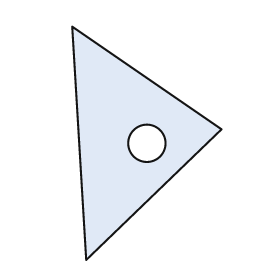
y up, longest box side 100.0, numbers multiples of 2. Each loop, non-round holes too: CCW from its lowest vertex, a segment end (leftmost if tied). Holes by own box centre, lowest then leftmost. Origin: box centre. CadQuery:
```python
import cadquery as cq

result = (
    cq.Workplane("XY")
    .moveTo(-26.0, -50.0)
    .lineTo(32.0, 6.0)
    .lineTo(-32.0, 50.0)
    .close()
    .moveTo(0.0, 0.0)
    .circle(8.0)
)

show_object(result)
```